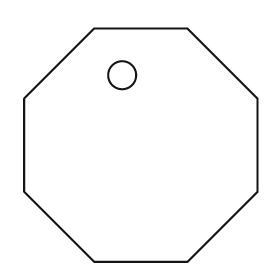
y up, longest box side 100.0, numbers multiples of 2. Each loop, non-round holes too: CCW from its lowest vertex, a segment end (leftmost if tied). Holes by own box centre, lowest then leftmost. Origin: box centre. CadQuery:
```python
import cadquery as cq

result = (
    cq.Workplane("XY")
    .moveTo(-20.0, -50.0)
    .lineTo(20.0, -50.0)
    .lineTo(50.0, -20.0)
    .lineTo(50.0, 20.0)
    .lineTo(20.0, 50.0)
    .lineTo(-20.0, 50.0)
    .lineTo(-50.0, 20.0)
    .lineTo(-50.0, -20.0)
    .close()
    .moveTo(-8.0, 30.0)
    .circle(6.0)
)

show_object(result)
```